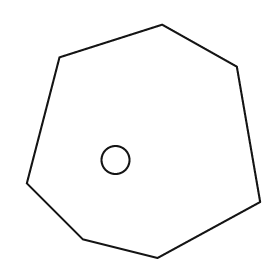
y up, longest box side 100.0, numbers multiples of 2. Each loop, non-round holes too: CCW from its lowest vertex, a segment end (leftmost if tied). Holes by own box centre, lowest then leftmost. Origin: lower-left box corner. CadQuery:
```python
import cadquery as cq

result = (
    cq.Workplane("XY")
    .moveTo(56.0, 0.0)
    .lineTo(100.0, 24.0)
    .lineTo(90.0, 82.0)
    .lineTo(58.0, 100.0)
    .lineTo(14.0, 86.0)
    .lineTo(0.0, 32.0)
    .lineTo(24.0, 8.0)
    .close()
    .moveTo(38.0, 42.0)
    .circle(6.0)
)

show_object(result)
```